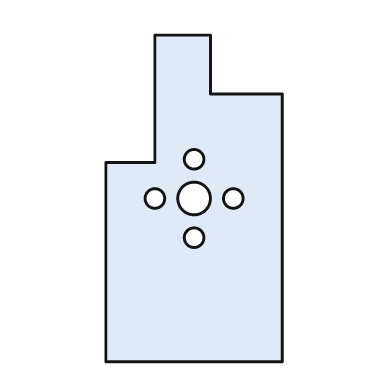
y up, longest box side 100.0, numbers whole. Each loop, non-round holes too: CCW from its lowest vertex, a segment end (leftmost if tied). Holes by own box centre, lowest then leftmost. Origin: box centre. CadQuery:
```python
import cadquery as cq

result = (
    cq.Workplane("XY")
    .moveTo(-27.0, -50.0)
    .lineTo(27.0, -50.0)
    .lineTo(27.0, 32.0)
    .lineTo(5.0, 32.0)
    .lineTo(5.0, 50.0)
    .lineTo(-12.0, 50.0)
    .lineTo(-12.0, 11.0)
    .lineTo(-27.0, 11.0)
    .close()
    .moveTo(0.0, -12.0)
    .circle(3.0)
    .moveTo(-12.0, 0.0)
    .circle(3.0)
    .moveTo(0.0, 0.0)
    .circle(5.0)
    .moveTo(12.0, 0.0)
    .circle(3.0)
    .moveTo(0.0, 12.0)
    .circle(3.0)
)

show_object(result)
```